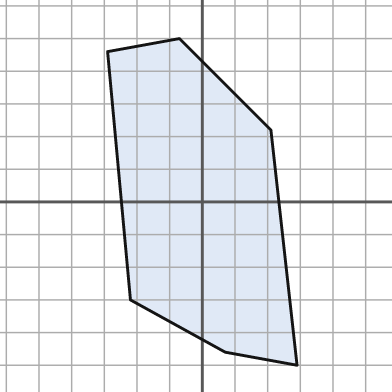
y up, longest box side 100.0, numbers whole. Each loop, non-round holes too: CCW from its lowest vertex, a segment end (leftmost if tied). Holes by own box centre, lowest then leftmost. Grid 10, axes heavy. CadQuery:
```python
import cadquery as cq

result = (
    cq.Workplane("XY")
    .moveTo(29.0, -50.0)
    .lineTo(21.0, 22.0)
    .lineTo(-7.0, 50.0)
    .lineTo(-29.0, 46.0)
    .lineTo(-22.0, -30.0)
    .lineTo(7.0, -46.0)
    .close()
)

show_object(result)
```